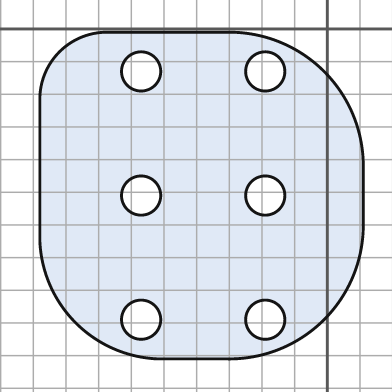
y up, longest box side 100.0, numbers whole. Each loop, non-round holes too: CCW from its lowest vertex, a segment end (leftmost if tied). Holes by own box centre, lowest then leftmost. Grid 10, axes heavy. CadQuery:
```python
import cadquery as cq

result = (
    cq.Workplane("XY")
    .moveTo(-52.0, -101.0)
    .lineTo(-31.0, -101.0)
    .threePointArc((-1.0, -89.0), (11.0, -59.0))
    .lineTo(11.0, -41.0)
    .threePointArc((-1.0, -13.0), (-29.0, -1.0))
    .lineTo(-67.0, -1.0)
    .threePointArc((-82.0, -7.0), (-88.0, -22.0))
    .lineTo(-88.0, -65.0)
    .threePointArc((-77.0, -90.0), (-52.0, -101.0))
    .close()
    .moveTo(-57.0, -89.0)
    .circle(6.0)
    .moveTo(-19.0, -89.0)
    .circle(6.0)
    .moveTo(-57.0, -51.0)
    .circle(6.0)
    .moveTo(-19.0, -51.0)
    .circle(6.0)
    .moveTo(-57.0, -13.0)
    .circle(6.0)
    .moveTo(-19.0, -13.0)
    .circle(6.0)
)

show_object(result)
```